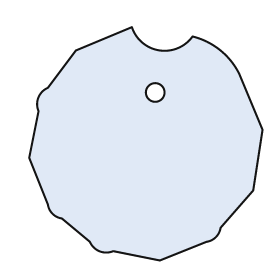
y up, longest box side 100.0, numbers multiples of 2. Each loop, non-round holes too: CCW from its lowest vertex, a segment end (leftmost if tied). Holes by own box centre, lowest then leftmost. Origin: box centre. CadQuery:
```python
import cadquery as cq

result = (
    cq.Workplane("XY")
    .moveTo(6.0, -50.0)
    .lineTo(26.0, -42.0)
    .threePointArc((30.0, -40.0), (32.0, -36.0))
    .lineTo(46.0, -20.0)
    .lineTo(50.0, 6.0)
    .lineTo(40.0, 30.0)
    .threePointArc((32.0, 40.0), (20.0, 46.0))
    .threePointArc((6.0, 40.0), (-6.0, 50.0))
    .lineTo(-30.0, 40.0)
    .lineTo(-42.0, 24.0)
    .threePointArc((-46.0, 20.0), (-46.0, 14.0))
    .lineTo(-50.0, -6.0)
    .lineTo(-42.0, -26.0)
    .threePointArc((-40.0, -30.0), (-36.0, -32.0))
    .lineTo(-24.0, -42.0)
    .threePointArc((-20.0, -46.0), (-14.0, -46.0))
    .close()
    .moveTo(4.0, 22.0)
    .circle(4.0)
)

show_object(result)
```